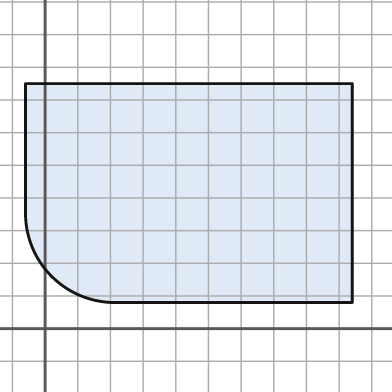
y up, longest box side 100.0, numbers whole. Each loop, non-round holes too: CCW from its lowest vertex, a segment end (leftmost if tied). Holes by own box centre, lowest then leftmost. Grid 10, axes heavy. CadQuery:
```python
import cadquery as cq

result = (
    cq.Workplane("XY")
    .moveTo(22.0, 8.0)
    .lineTo(94.0, 8.0)
    .lineTo(94.0, 75.0)
    .lineTo(-6.0, 75.0)
    .lineTo(-6.0, 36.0)
    .threePointArc((2.0, 16.0), (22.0, 8.0))
    .close()
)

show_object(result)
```